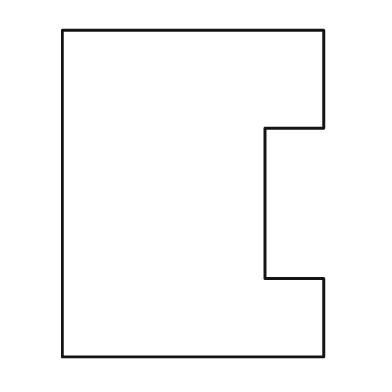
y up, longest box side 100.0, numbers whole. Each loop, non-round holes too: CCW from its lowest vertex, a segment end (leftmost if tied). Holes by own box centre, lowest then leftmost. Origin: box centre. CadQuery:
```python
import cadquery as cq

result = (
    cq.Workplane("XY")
    .moveTo(-40.0, -50.0)
    .lineTo(40.0, -50.0)
    .lineTo(40.0, -26.0)
    .lineTo(22.0, -26.0)
    .lineTo(22.0, 20.0)
    .lineTo(40.0, 20.0)
    .lineTo(40.0, 50.0)
    .lineTo(-40.0, 50.0)
    .close()
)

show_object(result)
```